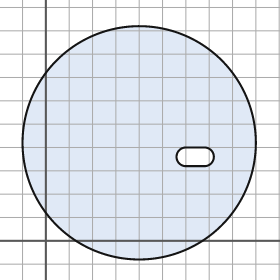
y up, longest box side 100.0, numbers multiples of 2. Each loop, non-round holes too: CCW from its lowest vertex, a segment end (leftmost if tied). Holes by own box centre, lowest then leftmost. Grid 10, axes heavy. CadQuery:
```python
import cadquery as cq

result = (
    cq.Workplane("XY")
    .moveTo(40.0, 42.0)
    .circle(50.0)
    .moveTo(60.0, 32.0)
    .lineTo(68.0, 32.0)
    .threePointArc((72.0, 36.0), (68.0, 40.0))
    .lineTo(60.0, 40.0)
    .threePointArc((56.0, 36.0), (60.0, 32.0))
    .close()
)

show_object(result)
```